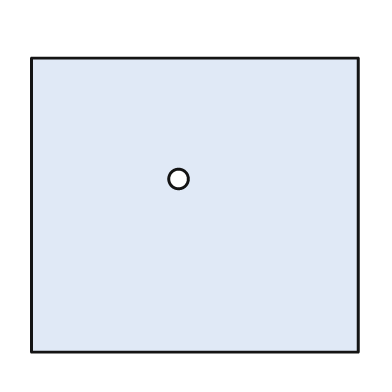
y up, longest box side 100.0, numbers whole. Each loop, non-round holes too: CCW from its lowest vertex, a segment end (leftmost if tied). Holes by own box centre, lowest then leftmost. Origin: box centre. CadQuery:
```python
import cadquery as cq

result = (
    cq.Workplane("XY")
    .moveTo(-50.0, -45.0)
    .lineTo(50.0, -45.0)
    .lineTo(50.0, 45.0)
    .lineTo(-50.0, 45.0)
    .close()
    .moveTo(-5.0, 8.0)
    .circle(3.0)
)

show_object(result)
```